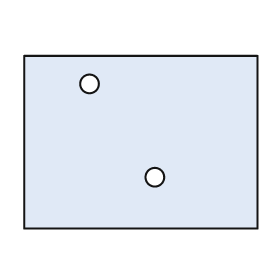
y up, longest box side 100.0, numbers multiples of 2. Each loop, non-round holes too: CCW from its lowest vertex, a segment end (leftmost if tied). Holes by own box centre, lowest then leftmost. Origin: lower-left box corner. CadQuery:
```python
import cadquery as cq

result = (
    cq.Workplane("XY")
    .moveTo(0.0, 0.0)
    .lineTo(100.0, 0.0)
    .lineTo(100.0, 74.0)
    .lineTo(0.0, 74.0)
    .close()
    .moveTo(56.0, 22.0)
    .circle(4.0)
    .moveTo(28.0, 62.0)
    .circle(4.0)
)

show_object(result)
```